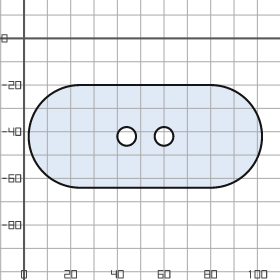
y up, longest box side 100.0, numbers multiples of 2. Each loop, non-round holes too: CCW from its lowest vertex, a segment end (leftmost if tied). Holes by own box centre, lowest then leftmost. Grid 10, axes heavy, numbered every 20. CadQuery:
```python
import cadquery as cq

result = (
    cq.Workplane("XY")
    .moveTo(24.0, -64.0)
    .lineTo(80.0, -64.0)
    .threePointArc((102.0, -42.0), (80.0, -20.0))
    .lineTo(24.0, -20.0)
    .threePointArc((2.0, -42.0), (24.0, -64.0))
    .close()
    .moveTo(44.0, -42.0)
    .circle(4.0)
    .moveTo(60.0, -42.0)
    .circle(4.0)
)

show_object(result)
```